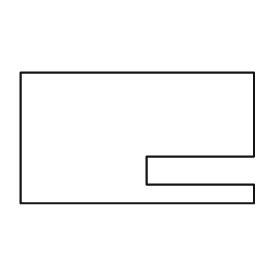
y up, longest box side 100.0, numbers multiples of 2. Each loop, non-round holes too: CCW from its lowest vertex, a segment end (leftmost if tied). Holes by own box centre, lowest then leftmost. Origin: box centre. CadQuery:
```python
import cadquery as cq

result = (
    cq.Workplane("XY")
    .moveTo(-50.0, -28.0)
    .lineTo(50.0, -28.0)
    .lineTo(50.0, -20.0)
    .lineTo(4.0, -20.0)
    .lineTo(4.0, -8.0)
    .lineTo(50.0, -8.0)
    .lineTo(50.0, 28.0)
    .lineTo(-50.0, 28.0)
    .close()
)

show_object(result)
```